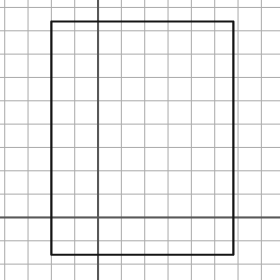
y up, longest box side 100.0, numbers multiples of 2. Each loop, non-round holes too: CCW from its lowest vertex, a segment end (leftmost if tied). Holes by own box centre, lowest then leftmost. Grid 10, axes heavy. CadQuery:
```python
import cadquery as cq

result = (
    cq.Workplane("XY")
    .moveTo(-20.0, -16.0)
    .lineTo(58.0, -16.0)
    .lineTo(58.0, 84.0)
    .lineTo(-20.0, 84.0)
    .close()
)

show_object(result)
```